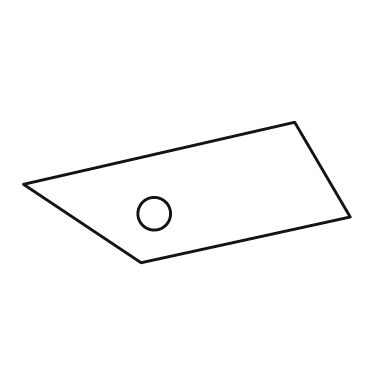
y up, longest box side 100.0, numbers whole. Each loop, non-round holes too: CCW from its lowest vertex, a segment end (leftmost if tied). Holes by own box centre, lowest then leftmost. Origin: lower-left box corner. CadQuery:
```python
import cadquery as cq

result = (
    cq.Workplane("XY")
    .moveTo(36.0, 0.0)
    .lineTo(100.0, 14.0)
    .lineTo(83.0, 43.0)
    .lineTo(0.0, 24.0)
    .close()
    .moveTo(40.0, 15.0)
    .circle(5.0)
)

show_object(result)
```